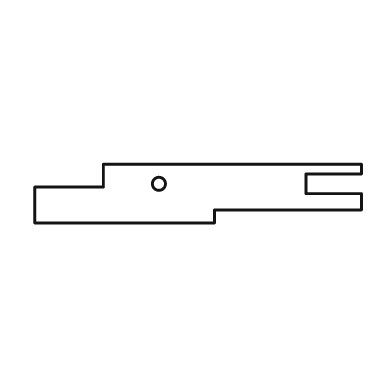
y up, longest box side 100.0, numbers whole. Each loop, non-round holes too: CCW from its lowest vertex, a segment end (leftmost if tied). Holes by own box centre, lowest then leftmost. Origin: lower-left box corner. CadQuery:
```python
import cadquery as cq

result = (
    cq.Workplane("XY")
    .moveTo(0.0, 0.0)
    .lineTo(55.0, 0.0)
    .lineTo(55.0, 4.0)
    .lineTo(100.0, 4.0)
    .lineTo(100.0, 9.0)
    .lineTo(83.0, 9.0)
    .lineTo(83.0, 15.0)
    .lineTo(100.0, 15.0)
    .lineTo(100.0, 18.0)
    .lineTo(21.0, 18.0)
    .lineTo(21.0, 11.0)
    .lineTo(0.0, 11.0)
    .close()
    .moveTo(38.0, 12.0)
    .circle(2.0)
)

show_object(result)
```